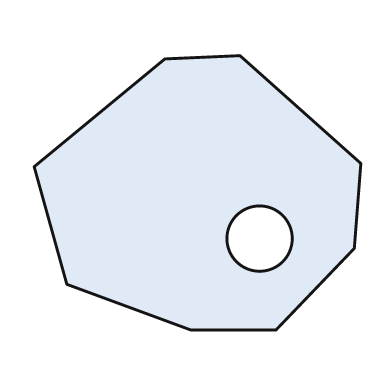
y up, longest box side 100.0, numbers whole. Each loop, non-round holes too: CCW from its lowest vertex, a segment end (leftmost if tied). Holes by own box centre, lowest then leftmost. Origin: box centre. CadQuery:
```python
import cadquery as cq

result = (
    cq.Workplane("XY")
    .moveTo(-2.0, -42.0)
    .lineTo(24.0, -42.0)
    .lineTo(48.0, -17.0)
    .lineTo(50.0, 9.0)
    .lineTo(13.0, 42.0)
    .lineTo(-10.0, 41.0)
    .lineTo(-50.0, 8.0)
    .lineTo(-40.0, -28.0)
    .close()
    .moveTo(19.0, -14.0)
    .circle(10.0)
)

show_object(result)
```